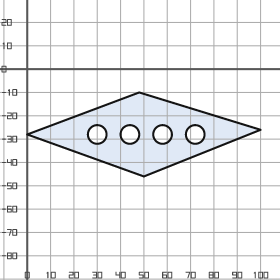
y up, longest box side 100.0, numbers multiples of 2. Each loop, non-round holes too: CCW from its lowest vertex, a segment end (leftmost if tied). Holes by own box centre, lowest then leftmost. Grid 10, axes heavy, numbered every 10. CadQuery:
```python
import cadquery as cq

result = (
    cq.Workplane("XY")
    .moveTo(50.0, -46.0)
    .lineTo(100.0, -26.0)
    .lineTo(48.0, -10.0)
    .lineTo(0.0, -28.0)
    .close()
    .moveTo(30.0, -28.0)
    .circle(4.0)
    .moveTo(44.0, -28.0)
    .circle(4.0)
    .moveTo(58.0, -28.0)
    .circle(4.0)
    .moveTo(72.0, -28.0)
    .circle(4.0)
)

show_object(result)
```